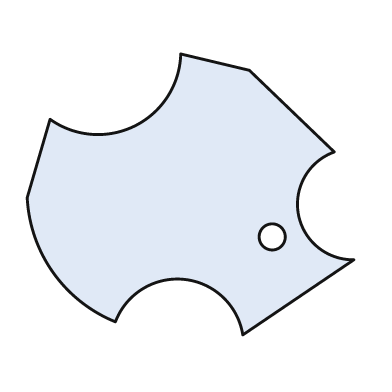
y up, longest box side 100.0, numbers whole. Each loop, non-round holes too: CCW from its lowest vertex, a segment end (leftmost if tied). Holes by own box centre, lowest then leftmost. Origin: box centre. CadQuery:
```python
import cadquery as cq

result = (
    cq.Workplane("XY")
    .moveTo(16.0, -43.0)
    .lineTo(50.0, -20.0)
    .threePointArc((33.0, -6.0), (44.0, 13.0))
    .lineTo(18.0, 38.0)
    .lineTo(-3.0, 43.0)
    .threePointArc((-17.0, 21.0), (-43.0, 23.0))
    .lineTo(-50.0, -1.0)
    .threePointArc((-42.0, -24.0), (-23.0, -39.0))
    .threePointArc((-2.0, -26.0), (16.0, -43.0))
    .close()
    .moveTo(25.0, -13.0)
    .circle(4.0)
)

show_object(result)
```